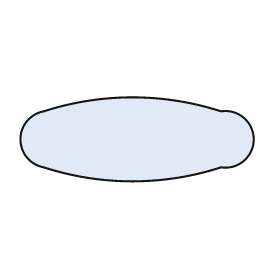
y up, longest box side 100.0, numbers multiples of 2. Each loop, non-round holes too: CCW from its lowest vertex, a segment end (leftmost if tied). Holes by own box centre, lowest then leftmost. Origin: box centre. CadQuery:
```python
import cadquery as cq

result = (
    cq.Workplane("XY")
    .moveTo(-40.0, -12.0)
    .threePointArc((-2.0, -18.0), (36.0, -12.0))
    .threePointArc((50.0, 0.0), (36.0, 12.0))
    .threePointArc((-2.0, 18.0), (-40.0, 12.0))
    .threePointArc((-50.0, 0.0), (-40.0, -12.0))
    .close()
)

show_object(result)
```